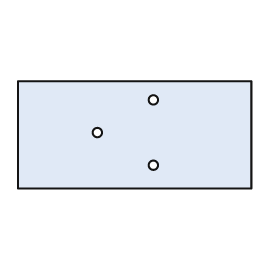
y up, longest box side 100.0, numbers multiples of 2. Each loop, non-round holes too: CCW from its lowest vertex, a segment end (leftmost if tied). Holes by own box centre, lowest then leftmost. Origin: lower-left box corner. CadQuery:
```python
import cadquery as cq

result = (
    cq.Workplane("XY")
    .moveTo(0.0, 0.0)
    .lineTo(100.0, 0.0)
    .lineTo(100.0, 46.0)
    .lineTo(0.0, 46.0)
    .close()
    .moveTo(58.0, 10.0)
    .circle(2.0)
    .moveTo(34.0, 24.0)
    .circle(2.0)
    .moveTo(58.0, 38.0)
    .circle(2.0)
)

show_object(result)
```